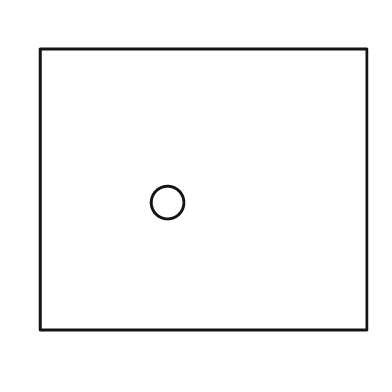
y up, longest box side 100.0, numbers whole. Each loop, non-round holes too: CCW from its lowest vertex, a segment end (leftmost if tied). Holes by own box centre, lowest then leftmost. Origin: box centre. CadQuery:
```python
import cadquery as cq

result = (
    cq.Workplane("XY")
    .moveTo(-50.0, -43.0)
    .lineTo(50.0, -43.0)
    .lineTo(50.0, 43.0)
    .lineTo(-50.0, 43.0)
    .close()
    .moveTo(-11.0, -4.0)
    .circle(5.0)
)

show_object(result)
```